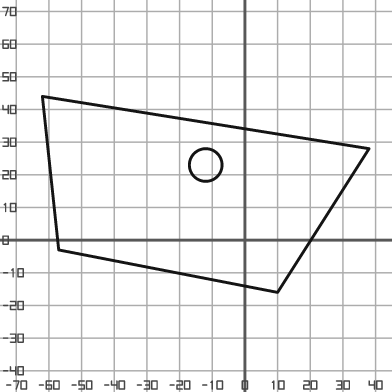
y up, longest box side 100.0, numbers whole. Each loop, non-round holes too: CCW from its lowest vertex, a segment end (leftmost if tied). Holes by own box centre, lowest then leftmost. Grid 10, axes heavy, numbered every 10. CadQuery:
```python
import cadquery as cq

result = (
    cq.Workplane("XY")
    .moveTo(10.0, -16.0)
    .lineTo(38.0, 28.0)
    .lineTo(-62.0, 44.0)
    .lineTo(-57.0, -3.0)
    .close()
    .moveTo(-12.0, 23.0)
    .circle(5.0)
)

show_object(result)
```